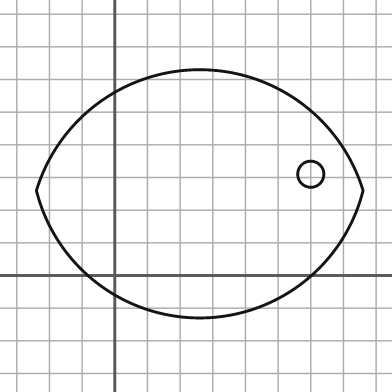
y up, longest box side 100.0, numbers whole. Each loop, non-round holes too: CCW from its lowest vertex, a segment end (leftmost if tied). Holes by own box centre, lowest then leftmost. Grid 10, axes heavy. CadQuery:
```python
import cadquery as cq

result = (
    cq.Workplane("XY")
    .moveTo(-24.0, 26.0)
    .threePointArc((26.0, -13.0), (76.0, 26.0))
    .threePointArc((26.0, 63.0), (-24.0, 26.0))
    .close()
    .moveTo(60.0, 31.0)
    .circle(4.0)
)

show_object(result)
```